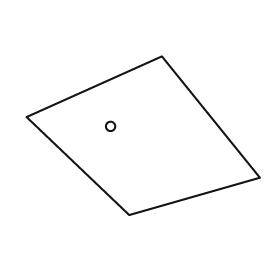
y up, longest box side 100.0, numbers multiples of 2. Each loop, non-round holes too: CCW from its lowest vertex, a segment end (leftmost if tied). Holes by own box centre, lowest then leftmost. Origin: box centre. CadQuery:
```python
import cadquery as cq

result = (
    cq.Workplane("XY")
    .moveTo(-6.0, -34.0)
    .lineTo(50.0, -18.0)
    .lineTo(8.0, 34.0)
    .lineTo(-50.0, 8.0)
    .close()
    .moveTo(-14.0, 4.0)
    .circle(2.0)
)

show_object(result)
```